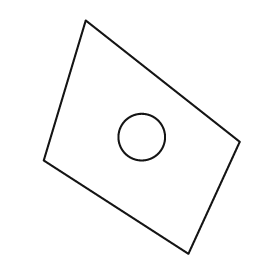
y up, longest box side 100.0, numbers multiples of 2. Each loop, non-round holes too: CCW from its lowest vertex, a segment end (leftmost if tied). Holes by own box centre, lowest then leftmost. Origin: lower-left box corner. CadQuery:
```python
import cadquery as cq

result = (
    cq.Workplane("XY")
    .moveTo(62.0, 0.0)
    .lineTo(84.0, 48.0)
    .lineTo(18.0, 100.0)
    .lineTo(0.0, 40.0)
    .close()
    .moveTo(42.0, 50.0)
    .circle(10.0)
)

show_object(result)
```